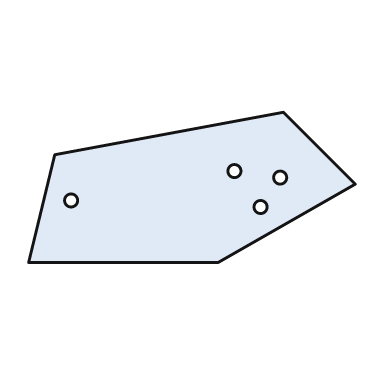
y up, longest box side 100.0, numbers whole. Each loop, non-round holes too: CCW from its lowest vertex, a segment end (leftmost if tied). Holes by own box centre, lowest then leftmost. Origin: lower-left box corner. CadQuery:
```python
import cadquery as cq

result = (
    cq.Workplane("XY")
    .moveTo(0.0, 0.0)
    .lineTo(58.0, 0.0)
    .lineTo(100.0, 24.0)
    .lineTo(78.0, 46.0)
    .lineTo(8.0, 33.0)
    .close()
    .moveTo(71.0, 17.0)
    .circle(2.0)
    .moveTo(13.0, 19.0)
    .circle(2.0)
    .moveTo(77.0, 26.0)
    .circle(2.0)
    .moveTo(63.0, 28.0)
    .circle(2.0)
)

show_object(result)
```